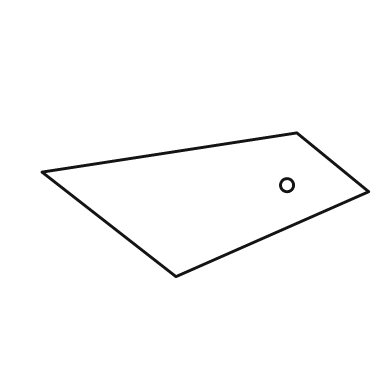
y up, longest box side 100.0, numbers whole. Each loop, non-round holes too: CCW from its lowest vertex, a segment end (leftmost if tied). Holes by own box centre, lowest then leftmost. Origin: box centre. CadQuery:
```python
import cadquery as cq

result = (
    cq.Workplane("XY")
    .moveTo(-9.0, -22.0)
    .lineTo(50.0, 4.0)
    .lineTo(28.0, 22.0)
    .lineTo(-50.0, 10.0)
    .close()
    .moveTo(25.0, 6.0)
    .circle(2.0)
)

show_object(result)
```